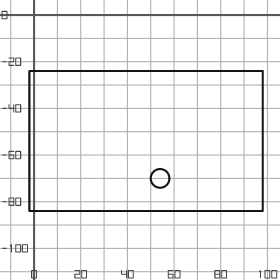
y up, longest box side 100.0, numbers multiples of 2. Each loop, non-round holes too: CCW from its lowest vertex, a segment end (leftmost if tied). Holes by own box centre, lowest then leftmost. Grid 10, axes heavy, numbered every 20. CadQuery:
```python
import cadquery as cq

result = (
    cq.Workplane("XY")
    .moveTo(-2.0, -84.0)
    .lineTo(98.0, -84.0)
    .lineTo(98.0, -24.0)
    .lineTo(-2.0, -24.0)
    .close()
    .moveTo(54.0, -70.0)
    .circle(4.0)
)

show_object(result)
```